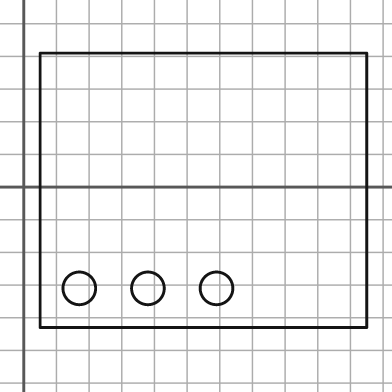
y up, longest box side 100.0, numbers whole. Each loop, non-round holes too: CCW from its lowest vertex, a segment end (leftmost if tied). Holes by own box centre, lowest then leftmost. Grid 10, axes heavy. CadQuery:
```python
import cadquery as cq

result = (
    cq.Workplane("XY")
    .moveTo(5.0, -43.0)
    .lineTo(105.0, -43.0)
    .lineTo(105.0, 41.0)
    .lineTo(5.0, 41.0)
    .close()
    .moveTo(17.0, -31.0)
    .circle(5.0)
    .moveTo(38.0, -31.0)
    .circle(5.0)
    .moveTo(59.0, -31.0)
    .circle(5.0)
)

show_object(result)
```